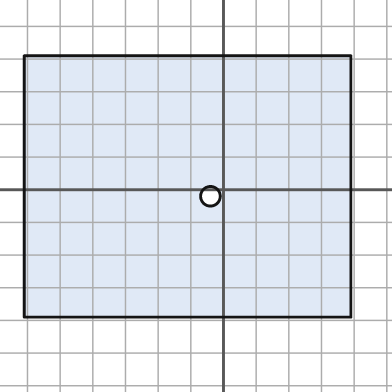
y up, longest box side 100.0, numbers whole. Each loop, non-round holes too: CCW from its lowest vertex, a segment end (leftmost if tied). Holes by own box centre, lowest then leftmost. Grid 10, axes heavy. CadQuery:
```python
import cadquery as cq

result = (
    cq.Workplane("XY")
    .moveTo(-61.0, -39.0)
    .lineTo(39.0, -39.0)
    .lineTo(39.0, 41.0)
    .lineTo(-61.0, 41.0)
    .close()
    .moveTo(-4.0, -2.0)
    .circle(3.0)
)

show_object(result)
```